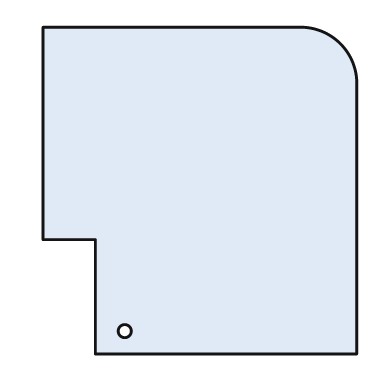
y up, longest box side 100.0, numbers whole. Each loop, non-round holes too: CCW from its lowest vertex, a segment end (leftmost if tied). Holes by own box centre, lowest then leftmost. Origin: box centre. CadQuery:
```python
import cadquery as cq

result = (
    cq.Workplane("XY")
    .moveTo(-32.0, -50.0)
    .lineTo(48.0, -50.0)
    .lineTo(48.0, 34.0)
    .threePointArc((43.0, 45.0), (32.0, 50.0))
    .lineTo(-48.0, 50.0)
    .lineTo(-48.0, -15.0)
    .lineTo(-32.0, -15.0)
    .close()
    .moveTo(-23.0, -43.0)
    .circle(2.0)
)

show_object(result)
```